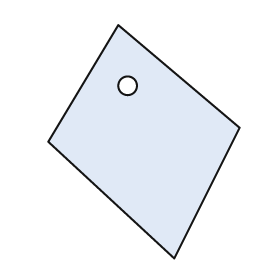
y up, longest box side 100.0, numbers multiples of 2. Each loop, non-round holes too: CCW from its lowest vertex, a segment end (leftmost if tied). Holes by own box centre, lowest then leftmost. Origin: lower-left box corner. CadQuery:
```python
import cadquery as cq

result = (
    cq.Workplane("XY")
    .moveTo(54.0, 0.0)
    .lineTo(82.0, 56.0)
    .lineTo(30.0, 100.0)
    .lineTo(0.0, 50.0)
    .close()
    .moveTo(34.0, 74.0)
    .circle(4.0)
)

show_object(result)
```